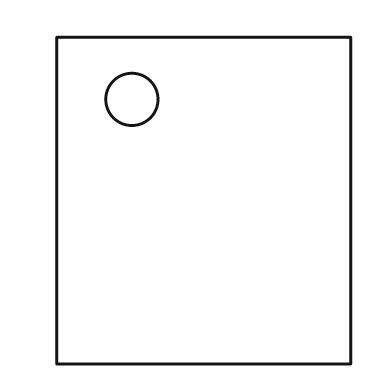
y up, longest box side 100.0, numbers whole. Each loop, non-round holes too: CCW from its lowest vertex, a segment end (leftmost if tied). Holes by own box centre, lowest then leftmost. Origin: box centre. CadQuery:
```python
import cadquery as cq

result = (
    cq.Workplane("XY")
    .moveTo(-45.0, -50.0)
    .lineTo(45.0, -50.0)
    .lineTo(45.0, 50.0)
    .lineTo(-45.0, 50.0)
    .close()
    .moveTo(-22.0, 31.0)
    .circle(8.0)
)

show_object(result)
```